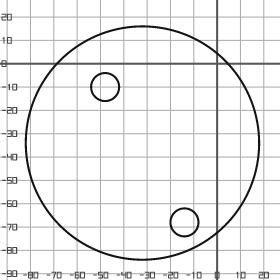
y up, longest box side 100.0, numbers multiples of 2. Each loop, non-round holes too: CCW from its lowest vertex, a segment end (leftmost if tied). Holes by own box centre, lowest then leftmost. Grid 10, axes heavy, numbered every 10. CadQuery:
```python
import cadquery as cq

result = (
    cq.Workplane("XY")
    .moveTo(-32.0, -34.0)
    .circle(50.0)
    .moveTo(-14.0, -68.0)
    .circle(6.0)
    .moveTo(-48.0, -10.0)
    .circle(6.0)
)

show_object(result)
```